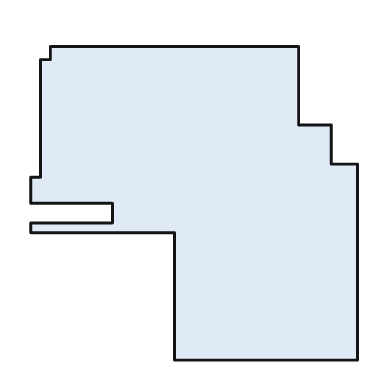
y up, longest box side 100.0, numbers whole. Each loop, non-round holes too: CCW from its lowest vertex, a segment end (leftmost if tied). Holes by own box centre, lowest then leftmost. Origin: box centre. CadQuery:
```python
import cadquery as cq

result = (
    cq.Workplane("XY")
    .moveTo(-6.0, -48.0)
    .lineTo(50.0, -48.0)
    .lineTo(50.0, 12.0)
    .lineTo(42.0, 12.0)
    .lineTo(42.0, 24.0)
    .lineTo(32.0, 24.0)
    .lineTo(32.0, 48.0)
    .lineTo(-44.0, 48.0)
    .lineTo(-44.0, 44.0)
    .lineTo(-47.0, 44.0)
    .lineTo(-47.0, 8.0)
    .lineTo(-50.0, 8.0)
    .lineTo(-50.0, 0.0)
    .lineTo(-25.0, 0.0)
    .lineTo(-25.0, -6.0)
    .lineTo(-50.0, -6.0)
    .lineTo(-50.0, -9.0)
    .lineTo(-6.0, -9.0)
    .close()
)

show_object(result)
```